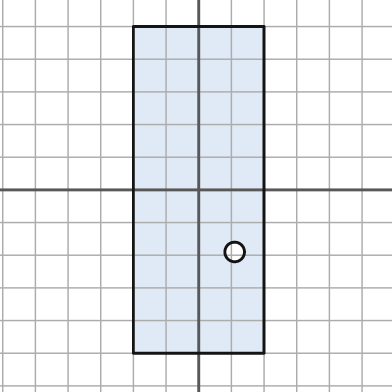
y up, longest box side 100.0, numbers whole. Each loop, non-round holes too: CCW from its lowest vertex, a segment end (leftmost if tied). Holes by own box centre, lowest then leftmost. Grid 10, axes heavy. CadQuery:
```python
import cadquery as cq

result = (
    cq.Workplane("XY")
    .moveTo(-20.0, -50.0)
    .lineTo(20.0, -50.0)
    .lineTo(20.0, 50.0)
    .lineTo(-20.0, 50.0)
    .close()
    .moveTo(11.0, -19.0)
    .circle(3.0)
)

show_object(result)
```